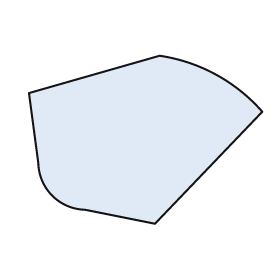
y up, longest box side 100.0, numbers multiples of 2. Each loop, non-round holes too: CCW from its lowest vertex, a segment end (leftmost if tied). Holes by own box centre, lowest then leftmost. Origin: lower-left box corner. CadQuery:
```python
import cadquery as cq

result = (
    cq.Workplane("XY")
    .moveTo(54.0, 0.0)
    .lineTo(100.0, 48.0)
    .threePointArc((80.0, 64.0), (56.0, 72.0))
    .lineTo(0.0, 56.0)
    .lineTo(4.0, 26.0)
    .threePointArc((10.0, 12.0), (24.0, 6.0))
    .close()
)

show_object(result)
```